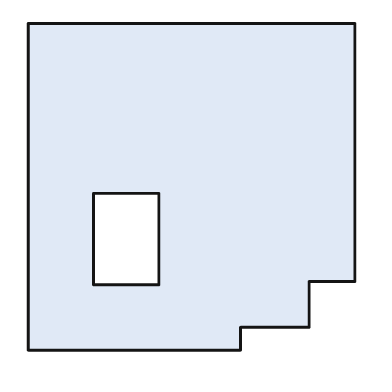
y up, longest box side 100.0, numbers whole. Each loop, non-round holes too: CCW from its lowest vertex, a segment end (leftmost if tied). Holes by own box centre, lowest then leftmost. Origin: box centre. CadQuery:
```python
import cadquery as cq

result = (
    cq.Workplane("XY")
    .moveTo(-50.0, -50.0)
    .lineTo(15.0, -50.0)
    .lineTo(15.0, -43.0)
    .lineTo(36.0, -43.0)
    .lineTo(36.0, -29.0)
    .lineTo(50.0, -29.0)
    .lineTo(50.0, 50.0)
    .lineTo(-50.0, 50.0)
    .close()
    .moveTo(-30.0, -30.0)
    .lineTo(-10.0, -30.0)
    .lineTo(-10.0, -2.0)
    .lineTo(-30.0, -2.0)
    .close()
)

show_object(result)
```